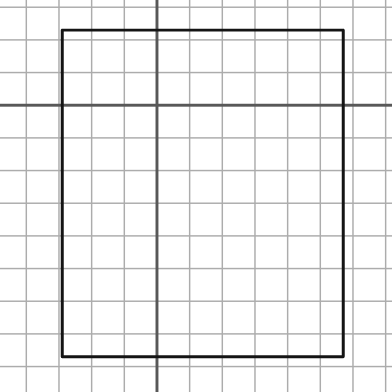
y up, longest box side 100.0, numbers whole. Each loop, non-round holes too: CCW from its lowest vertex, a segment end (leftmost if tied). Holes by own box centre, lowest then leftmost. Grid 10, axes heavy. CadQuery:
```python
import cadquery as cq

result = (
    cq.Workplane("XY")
    .moveTo(-29.0, -77.0)
    .lineTo(57.0, -77.0)
    .lineTo(57.0, 23.0)
    .lineTo(-29.0, 23.0)
    .close()
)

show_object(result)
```